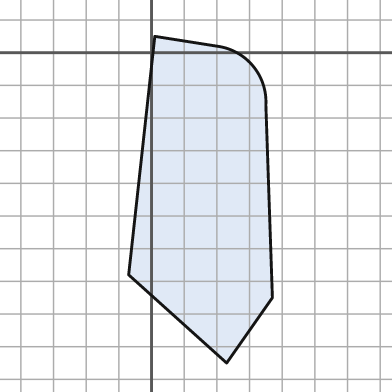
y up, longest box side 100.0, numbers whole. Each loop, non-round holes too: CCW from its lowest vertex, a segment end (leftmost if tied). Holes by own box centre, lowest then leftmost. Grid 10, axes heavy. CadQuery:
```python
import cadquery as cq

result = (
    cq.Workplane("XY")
    .moveTo(23.0, -95.0)
    .lineTo(37.0, -75.0)
    .lineTo(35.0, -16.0)
    .threePointArc((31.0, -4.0), (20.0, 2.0))
    .lineTo(1.0, 5.0)
    .lineTo(-7.0, -68.0)
    .close()
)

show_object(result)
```